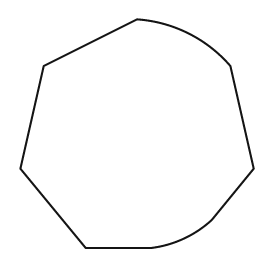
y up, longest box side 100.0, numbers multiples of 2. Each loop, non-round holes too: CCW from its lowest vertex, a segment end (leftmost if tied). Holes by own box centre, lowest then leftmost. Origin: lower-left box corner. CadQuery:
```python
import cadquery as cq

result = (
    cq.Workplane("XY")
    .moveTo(28.0, 0.0)
    .lineTo(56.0, 0.0)
    .threePointArc((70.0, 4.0), (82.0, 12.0))
    .lineTo(100.0, 34.0)
    .lineTo(90.0, 78.0)
    .threePointArc((72.0, 92.0), (50.0, 98.0))
    .lineTo(10.0, 78.0)
    .lineTo(0.0, 34.0)
    .close()
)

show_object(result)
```